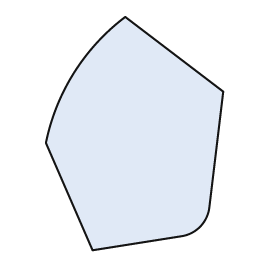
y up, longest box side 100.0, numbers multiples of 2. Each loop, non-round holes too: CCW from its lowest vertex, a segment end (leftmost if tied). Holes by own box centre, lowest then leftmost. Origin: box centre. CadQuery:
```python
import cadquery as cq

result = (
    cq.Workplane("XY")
    .moveTo(-18.0, -50.0)
    .lineTo(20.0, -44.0)
    .threePointArc((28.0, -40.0), (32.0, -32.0))
    .lineTo(38.0, 18.0)
    .lineTo(-4.0, 50.0)
    .threePointArc((-26.0, 26.0), (-38.0, -4.0))
    .close()
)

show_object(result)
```